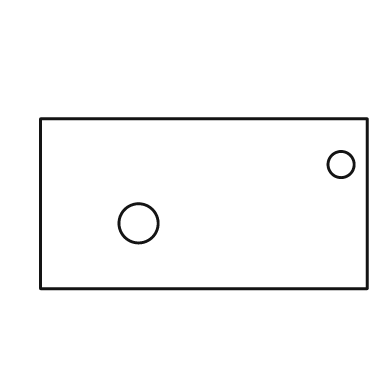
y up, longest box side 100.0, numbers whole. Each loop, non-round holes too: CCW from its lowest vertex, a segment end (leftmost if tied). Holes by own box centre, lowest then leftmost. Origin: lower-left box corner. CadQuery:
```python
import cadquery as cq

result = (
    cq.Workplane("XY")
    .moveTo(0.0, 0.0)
    .lineTo(100.0, 0.0)
    .lineTo(100.0, 52.0)
    .lineTo(0.0, 52.0)
    .close()
    .moveTo(30.0, 20.0)
    .circle(6.0)
    .moveTo(92.0, 38.0)
    .circle(4.0)
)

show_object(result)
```